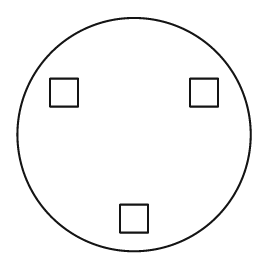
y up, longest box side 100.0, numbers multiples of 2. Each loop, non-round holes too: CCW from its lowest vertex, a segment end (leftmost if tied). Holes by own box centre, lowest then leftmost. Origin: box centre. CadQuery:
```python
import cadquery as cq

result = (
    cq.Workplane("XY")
    .moveTo(0.0, 0.0)
    .circle(50.0)
    .moveTo(-6.0, -42.0)
    .lineTo(6.0, -42.0)
    .lineTo(6.0, -30.0)
    .lineTo(-6.0, -30.0)
    .close()
    .moveTo(-36.0, 12.0)
    .lineTo(-24.0, 12.0)
    .lineTo(-24.0, 24.0)
    .lineTo(-36.0, 24.0)
    .close()
    .moveTo(24.0, 12.0)
    .lineTo(36.0, 12.0)
    .lineTo(36.0, 24.0)
    .lineTo(24.0, 24.0)
    .close()
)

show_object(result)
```